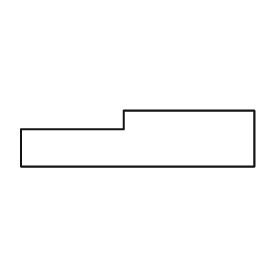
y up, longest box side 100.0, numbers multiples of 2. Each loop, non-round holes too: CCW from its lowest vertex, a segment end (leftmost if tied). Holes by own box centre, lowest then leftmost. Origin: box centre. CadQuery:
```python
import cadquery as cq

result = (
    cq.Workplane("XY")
    .moveTo(-50.0, -12.0)
    .lineTo(50.0, -12.0)
    .lineTo(50.0, 12.0)
    .lineTo(-6.0, 12.0)
    .lineTo(-6.0, 4.0)
    .lineTo(-50.0, 4.0)
    .close()
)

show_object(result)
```